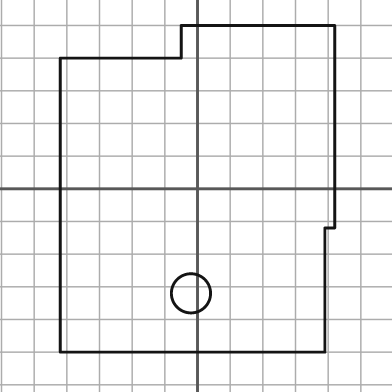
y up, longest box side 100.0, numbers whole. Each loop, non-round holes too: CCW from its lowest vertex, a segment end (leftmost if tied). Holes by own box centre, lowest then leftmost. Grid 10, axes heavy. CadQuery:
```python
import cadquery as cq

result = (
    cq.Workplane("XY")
    .moveTo(-42.0, -50.0)
    .lineTo(39.0, -50.0)
    .lineTo(39.0, -12.0)
    .lineTo(42.0, -12.0)
    .lineTo(42.0, 50.0)
    .lineTo(-5.0, 50.0)
    .lineTo(-5.0, 40.0)
    .lineTo(-42.0, 40.0)
    .close()
    .moveTo(-2.0, -32.0)
    .circle(6.0)
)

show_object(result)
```